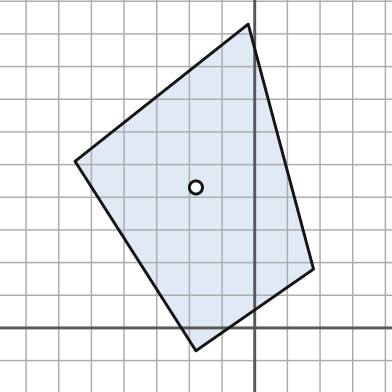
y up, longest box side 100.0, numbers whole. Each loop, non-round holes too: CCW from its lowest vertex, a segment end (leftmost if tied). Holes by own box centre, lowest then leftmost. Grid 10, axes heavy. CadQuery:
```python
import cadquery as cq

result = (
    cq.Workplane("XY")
    .moveTo(-18.0, -7.0)
    .lineTo(18.0, 18.0)
    .lineTo(-2.0, 93.0)
    .lineTo(-55.0, 51.0)
    .close()
    .moveTo(-18.0, 43.0)
    .circle(2.0)
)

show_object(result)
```